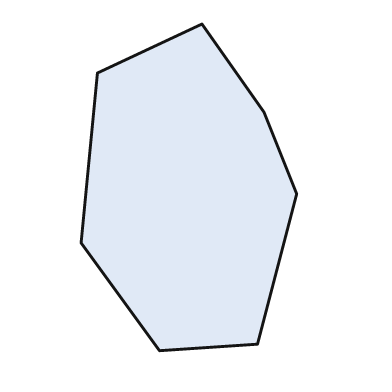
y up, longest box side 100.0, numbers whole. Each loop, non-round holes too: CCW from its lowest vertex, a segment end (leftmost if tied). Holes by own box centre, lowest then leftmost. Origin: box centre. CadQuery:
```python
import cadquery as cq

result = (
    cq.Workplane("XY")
    .moveTo(-9.0, -50.0)
    .lineTo(21.0, -48.0)
    .lineTo(33.0, -2.0)
    .lineTo(23.0, 23.0)
    .lineTo(4.0, 50.0)
    .lineTo(-28.0, 35.0)
    .lineTo(-33.0, -17.0)
    .close()
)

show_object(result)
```